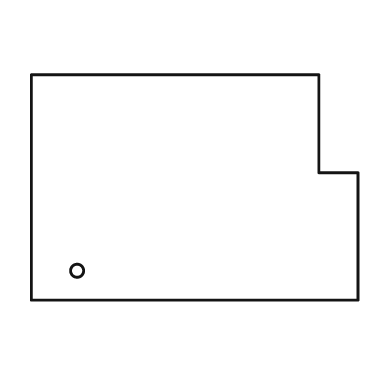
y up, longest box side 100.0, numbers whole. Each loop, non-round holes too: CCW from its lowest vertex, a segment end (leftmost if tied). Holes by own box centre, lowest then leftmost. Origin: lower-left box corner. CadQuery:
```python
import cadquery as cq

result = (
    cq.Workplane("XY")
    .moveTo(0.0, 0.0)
    .lineTo(100.0, 0.0)
    .lineTo(100.0, 39.0)
    .lineTo(88.0, 39.0)
    .lineTo(88.0, 69.0)
    .lineTo(0.0, 69.0)
    .close()
    .moveTo(14.0, 9.0)
    .circle(2.0)
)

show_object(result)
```